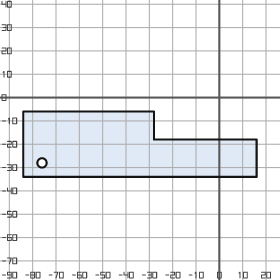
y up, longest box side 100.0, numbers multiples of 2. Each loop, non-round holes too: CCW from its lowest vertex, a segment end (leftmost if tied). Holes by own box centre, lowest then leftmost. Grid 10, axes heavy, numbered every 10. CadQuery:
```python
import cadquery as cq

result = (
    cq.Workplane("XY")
    .moveTo(-84.0, -34.0)
    .lineTo(16.0, -34.0)
    .lineTo(16.0, -18.0)
    .lineTo(-28.0, -18.0)
    .lineTo(-28.0, -6.0)
    .lineTo(-84.0, -6.0)
    .close()
    .moveTo(-76.0, -28.0)
    .circle(2.0)
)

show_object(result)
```